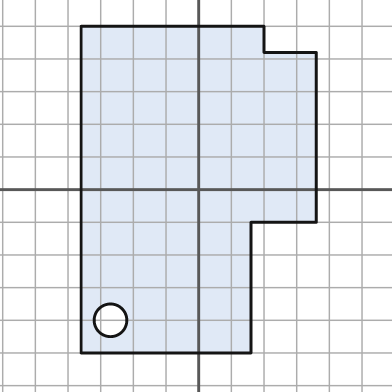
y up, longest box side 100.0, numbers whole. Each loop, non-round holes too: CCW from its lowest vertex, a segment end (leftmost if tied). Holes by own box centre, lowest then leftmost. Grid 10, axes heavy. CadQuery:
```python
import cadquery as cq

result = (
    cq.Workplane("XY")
    .moveTo(-36.0, -50.0)
    .lineTo(16.0, -50.0)
    .lineTo(16.0, -10.0)
    .lineTo(36.0, -10.0)
    .lineTo(36.0, 42.0)
    .lineTo(20.0, 42.0)
    .lineTo(20.0, 50.0)
    .lineTo(-36.0, 50.0)
    .close()
    .moveTo(-27.0, -40.0)
    .circle(5.0)
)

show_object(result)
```